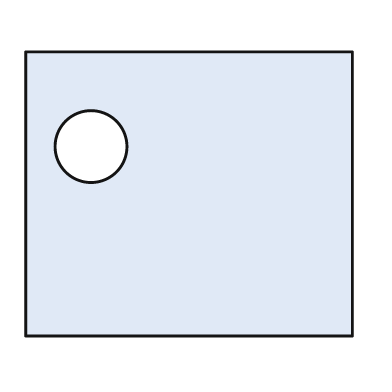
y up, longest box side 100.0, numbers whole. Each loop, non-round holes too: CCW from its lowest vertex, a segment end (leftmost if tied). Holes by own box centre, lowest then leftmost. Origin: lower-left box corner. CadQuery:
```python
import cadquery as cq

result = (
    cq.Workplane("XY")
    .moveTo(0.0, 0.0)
    .lineTo(100.0, 0.0)
    .lineTo(100.0, 87.0)
    .lineTo(0.0, 87.0)
    .close()
    .moveTo(20.0, 58.0)
    .circle(11.0)
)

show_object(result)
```